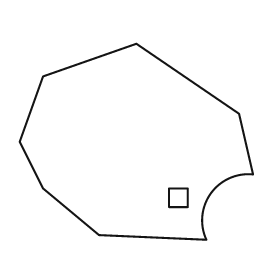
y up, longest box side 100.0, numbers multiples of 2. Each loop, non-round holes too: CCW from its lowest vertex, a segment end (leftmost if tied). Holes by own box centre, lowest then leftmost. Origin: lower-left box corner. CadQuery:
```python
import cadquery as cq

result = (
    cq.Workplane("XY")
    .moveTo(80.0, 0.0)
    .threePointArc((82.0, 20.0), (100.0, 28.0))
    .lineTo(94.0, 54.0)
    .lineTo(50.0, 84.0)
    .lineTo(10.0, 70.0)
    .lineTo(0.0, 42.0)
    .lineTo(10.0, 22.0)
    .lineTo(34.0, 2.0)
    .close()
    .moveTo(64.0, 14.0)
    .lineTo(72.0, 14.0)
    .lineTo(72.0, 22.0)
    .lineTo(64.0, 22.0)
    .close()
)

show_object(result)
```